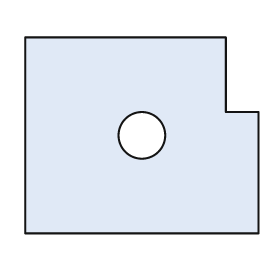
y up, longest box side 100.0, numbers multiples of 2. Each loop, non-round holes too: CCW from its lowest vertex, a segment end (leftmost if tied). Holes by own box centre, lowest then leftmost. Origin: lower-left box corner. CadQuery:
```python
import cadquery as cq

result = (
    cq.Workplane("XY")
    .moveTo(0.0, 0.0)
    .lineTo(100.0, 0.0)
    .lineTo(100.0, 52.0)
    .lineTo(86.0, 52.0)
    .lineTo(86.0, 84.0)
    .lineTo(0.0, 84.0)
    .close()
    .moveTo(50.0, 42.0)
    .circle(10.0)
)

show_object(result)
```